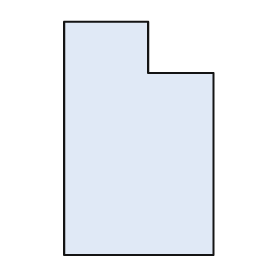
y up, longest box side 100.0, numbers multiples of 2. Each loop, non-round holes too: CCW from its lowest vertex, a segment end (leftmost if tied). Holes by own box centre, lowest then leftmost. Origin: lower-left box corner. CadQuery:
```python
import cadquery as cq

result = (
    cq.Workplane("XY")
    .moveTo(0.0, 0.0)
    .lineTo(64.0, 0.0)
    .lineTo(64.0, 78.0)
    .lineTo(36.0, 78.0)
    .lineTo(36.0, 100.0)
    .lineTo(0.0, 100.0)
    .close()
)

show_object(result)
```